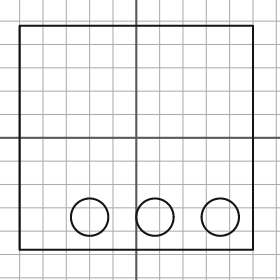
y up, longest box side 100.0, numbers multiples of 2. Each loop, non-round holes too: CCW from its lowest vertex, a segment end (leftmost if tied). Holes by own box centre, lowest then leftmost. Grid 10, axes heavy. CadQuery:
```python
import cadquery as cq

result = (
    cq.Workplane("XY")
    .moveTo(-50.0, -48.0)
    .lineTo(50.0, -48.0)
    .lineTo(50.0, 48.0)
    .lineTo(-50.0, 48.0)
    .close()
    .moveTo(-20.0, -34.0)
    .circle(8.0)
    .moveTo(8.0, -34.0)
    .circle(8.0)
    .moveTo(36.0, -34.0)
    .circle(8.0)
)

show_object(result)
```